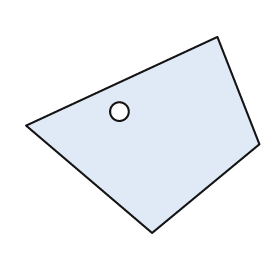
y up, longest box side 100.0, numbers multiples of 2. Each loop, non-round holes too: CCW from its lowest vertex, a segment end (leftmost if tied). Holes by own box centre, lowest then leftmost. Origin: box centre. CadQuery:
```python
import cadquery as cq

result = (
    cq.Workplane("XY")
    .moveTo(4.0, -42.0)
    .lineTo(50.0, -4.0)
    .lineTo(32.0, 42.0)
    .lineTo(-50.0, 4.0)
    .close()
    .moveTo(-10.0, 10.0)
    .circle(4.0)
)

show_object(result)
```